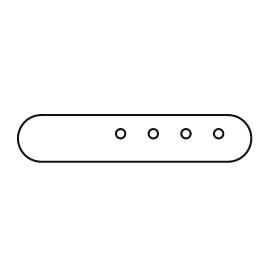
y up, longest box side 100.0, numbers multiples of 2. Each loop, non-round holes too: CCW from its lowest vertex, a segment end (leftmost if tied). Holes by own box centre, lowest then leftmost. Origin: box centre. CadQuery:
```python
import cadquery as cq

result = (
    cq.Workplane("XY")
    .moveTo(-40.0, -10.0)
    .lineTo(40.0, -10.0)
    .threePointArc((50.0, 0.0), (40.0, 10.0))
    .lineTo(-40.0, 10.0)
    .threePointArc((-50.0, 0.0), (-40.0, -10.0))
    .close()
    .moveTo(-6.0, 2.0)
    .circle(2.0)
    .moveTo(8.0, 2.0)
    .circle(2.0)
    .moveTo(22.0, 2.0)
    .circle(2.0)
    .moveTo(36.0, 2.0)
    .circle(2.0)
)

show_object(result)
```